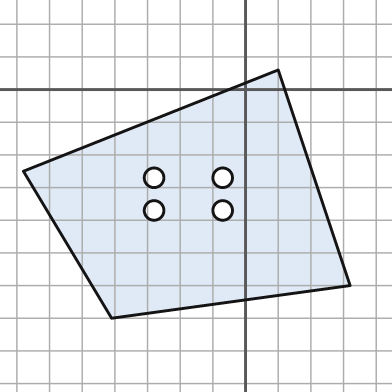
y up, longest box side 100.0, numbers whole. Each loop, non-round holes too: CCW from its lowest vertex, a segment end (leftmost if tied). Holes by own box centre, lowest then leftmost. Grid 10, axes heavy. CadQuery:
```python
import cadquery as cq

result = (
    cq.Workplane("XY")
    .moveTo(-41.0, -70.0)
    .lineTo(32.0, -60.0)
    .lineTo(10.0, 6.0)
    .lineTo(-68.0, -25.0)
    .close()
    .moveTo(-28.0, -37.0)
    .circle(3.0)
    .moveTo(-7.0, -37.0)
    .circle(3.0)
    .moveTo(-28.0, -27.0)
    .circle(3.0)
    .moveTo(-7.0, -27.0)
    .circle(3.0)
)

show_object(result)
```